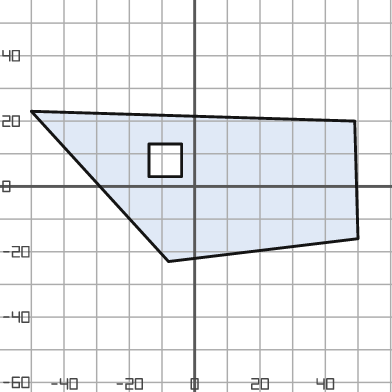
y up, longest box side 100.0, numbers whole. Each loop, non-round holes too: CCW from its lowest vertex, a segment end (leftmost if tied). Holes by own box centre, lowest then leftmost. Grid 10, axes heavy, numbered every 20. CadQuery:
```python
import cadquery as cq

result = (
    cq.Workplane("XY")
    .moveTo(-8.0, -23.0)
    .lineTo(50.0, -16.0)
    .lineTo(49.0, 20.0)
    .lineTo(-50.0, 23.0)
    .close()
    .moveTo(-14.0, 3.0)
    .lineTo(-4.0, 3.0)
    .lineTo(-4.0, 13.0)
    .lineTo(-14.0, 13.0)
    .close()
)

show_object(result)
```